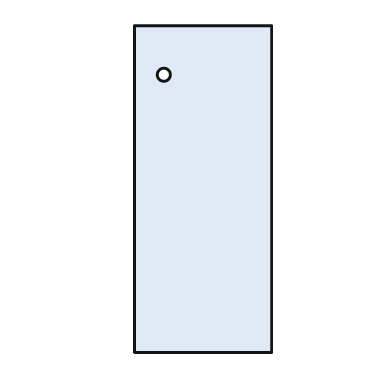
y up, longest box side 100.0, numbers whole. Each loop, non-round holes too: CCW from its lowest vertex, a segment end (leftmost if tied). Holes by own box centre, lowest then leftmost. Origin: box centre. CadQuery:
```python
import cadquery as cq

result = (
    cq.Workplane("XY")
    .moveTo(-21.0, -50.0)
    .lineTo(21.0, -50.0)
    .lineTo(21.0, 50.0)
    .lineTo(-21.0, 50.0)
    .close()
    .moveTo(-12.0, 35.0)
    .circle(2.0)
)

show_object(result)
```